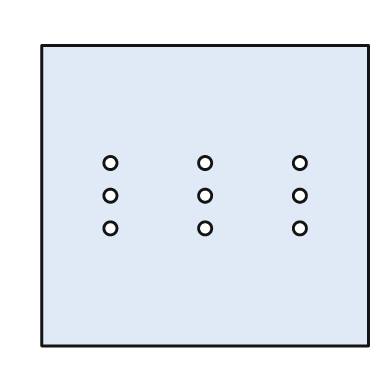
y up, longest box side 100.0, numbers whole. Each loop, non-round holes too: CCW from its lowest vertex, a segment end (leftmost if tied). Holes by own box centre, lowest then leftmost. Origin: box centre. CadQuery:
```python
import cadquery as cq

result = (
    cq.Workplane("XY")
    .moveTo(-50.0, -46.0)
    .lineTo(50.0, -46.0)
    .lineTo(50.0, 46.0)
    .lineTo(-50.0, 46.0)
    .close()
    .moveTo(-29.0, -10.0)
    .circle(2.0)
    .moveTo(0.0, -10.0)
    .circle(2.0)
    .moveTo(29.0, -10.0)
    .circle(2.0)
    .moveTo(-29.0, 0.0)
    .circle(2.0)
    .moveTo(0.0, 0.0)
    .circle(2.0)
    .moveTo(29.0, 0.0)
    .circle(2.0)
    .moveTo(-29.0, 10.0)
    .circle(2.0)
    .moveTo(0.0, 10.0)
    .circle(2.0)
    .moveTo(29.0, 10.0)
    .circle(2.0)
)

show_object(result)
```